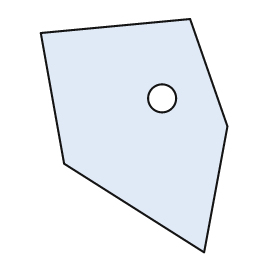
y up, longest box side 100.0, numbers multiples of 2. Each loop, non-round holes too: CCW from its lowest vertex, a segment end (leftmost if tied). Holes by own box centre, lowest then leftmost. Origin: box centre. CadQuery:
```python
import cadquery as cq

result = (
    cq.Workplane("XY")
    .moveTo(30.0, -50.0)
    .lineTo(40.0, 4.0)
    .lineTo(24.0, 50.0)
    .lineTo(-40.0, 44.0)
    .lineTo(-30.0, -12.0)
    .close()
    .moveTo(12.0, 16.0)
    .circle(6.0)
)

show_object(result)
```